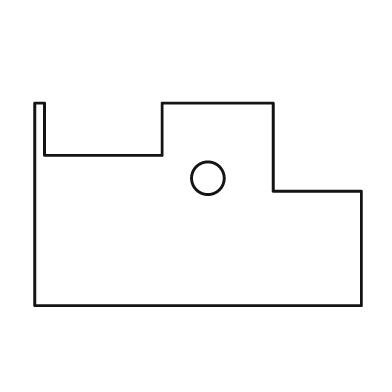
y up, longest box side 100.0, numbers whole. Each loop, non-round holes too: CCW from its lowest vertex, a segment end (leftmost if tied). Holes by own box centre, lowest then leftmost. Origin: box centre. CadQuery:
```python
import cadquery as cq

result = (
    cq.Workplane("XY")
    .moveTo(-50.0, -31.0)
    .lineTo(50.0, -31.0)
    .lineTo(50.0, 4.0)
    .lineTo(23.0, 4.0)
    .lineTo(23.0, 31.0)
    .lineTo(-11.0, 31.0)
    .lineTo(-11.0, 15.0)
    .lineTo(-47.0, 15.0)
    .lineTo(-47.0, 31.0)
    .lineTo(-50.0, 31.0)
    .close()
    .moveTo(3.0, 8.0)
    .circle(5.0)
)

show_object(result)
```